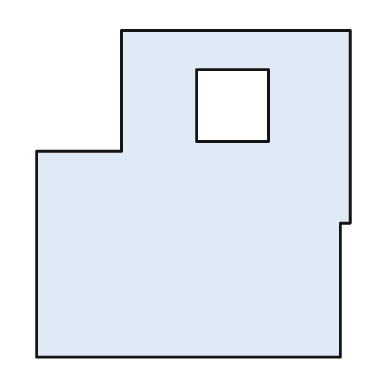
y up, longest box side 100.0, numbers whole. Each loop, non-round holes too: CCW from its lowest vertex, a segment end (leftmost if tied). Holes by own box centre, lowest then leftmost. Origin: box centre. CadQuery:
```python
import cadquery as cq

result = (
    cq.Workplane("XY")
    .moveTo(-48.0, -50.0)
    .lineTo(45.0, -50.0)
    .lineTo(45.0, -9.0)
    .lineTo(48.0, -9.0)
    .lineTo(48.0, 50.0)
    .lineTo(-22.0, 50.0)
    .lineTo(-22.0, 13.0)
    .lineTo(-48.0, 13.0)
    .close()
    .moveTo(1.0, 16.0)
    .lineTo(23.0, 16.0)
    .lineTo(23.0, 38.0)
    .lineTo(1.0, 38.0)
    .close()
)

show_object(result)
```